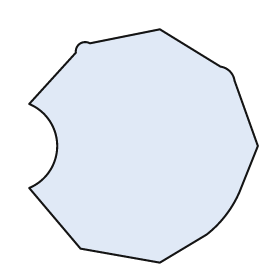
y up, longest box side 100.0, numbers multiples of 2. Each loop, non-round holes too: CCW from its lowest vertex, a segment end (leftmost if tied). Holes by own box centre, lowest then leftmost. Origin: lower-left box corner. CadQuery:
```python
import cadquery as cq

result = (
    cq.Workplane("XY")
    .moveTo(56.0, 0.0)
    .lineTo(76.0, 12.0)
    .threePointArc((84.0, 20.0), (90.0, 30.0))
    .lineTo(98.0, 50.0)
    .lineTo(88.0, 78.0)
    .threePointArc((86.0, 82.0), (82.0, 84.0))
    .lineTo(56.0, 100.0)
    .lineTo(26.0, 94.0)
    .threePointArc((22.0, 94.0), (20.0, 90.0))
    .lineTo(0.0, 68.0)
    .threePointArc((12.0, 50.0), (0.0, 32.0))
    .lineTo(22.0, 6.0)
    .close()
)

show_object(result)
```